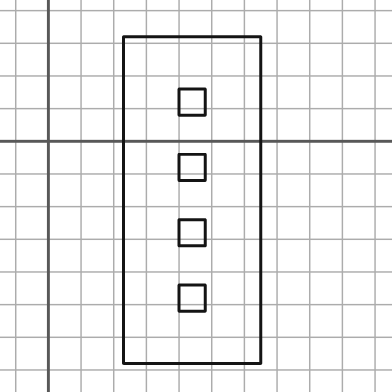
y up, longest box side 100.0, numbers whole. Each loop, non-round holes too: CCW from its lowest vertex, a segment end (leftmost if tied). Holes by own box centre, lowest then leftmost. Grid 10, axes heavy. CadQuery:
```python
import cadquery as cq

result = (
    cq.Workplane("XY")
    .moveTo(23.0, -68.0)
    .lineTo(65.0, -68.0)
    .lineTo(65.0, 32.0)
    .lineTo(23.0, 32.0)
    .close()
    .moveTo(40.0, -52.0)
    .lineTo(48.0, -52.0)
    .lineTo(48.0, -44.0)
    .lineTo(40.0, -44.0)
    .close()
    .moveTo(40.0, -32.0)
    .lineTo(48.0, -32.0)
    .lineTo(48.0, -24.0)
    .lineTo(40.0, -24.0)
    .close()
    .moveTo(40.0, -12.0)
    .lineTo(48.0, -12.0)
    .lineTo(48.0, -4.0)
    .lineTo(40.0, -4.0)
    .close()
    .moveTo(40.0, 8.0)
    .lineTo(48.0, 8.0)
    .lineTo(48.0, 16.0)
    .lineTo(40.0, 16.0)
    .close()
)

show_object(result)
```